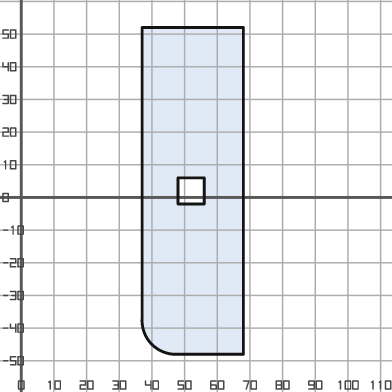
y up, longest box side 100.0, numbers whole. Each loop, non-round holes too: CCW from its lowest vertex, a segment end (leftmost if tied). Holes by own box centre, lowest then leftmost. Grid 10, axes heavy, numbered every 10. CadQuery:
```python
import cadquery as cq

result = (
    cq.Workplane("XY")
    .moveTo(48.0, -48.0)
    .lineTo(68.0, -48.0)
    .lineTo(68.0, 52.0)
    .lineTo(37.0, 52.0)
    .lineTo(37.0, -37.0)
    .threePointArc((40.0, -45.0), (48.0, -48.0))
    .close()
    .moveTo(48.0, -2.0)
    .lineTo(56.0, -2.0)
    .lineTo(56.0, 6.0)
    .lineTo(48.0, 6.0)
    .close()
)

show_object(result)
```